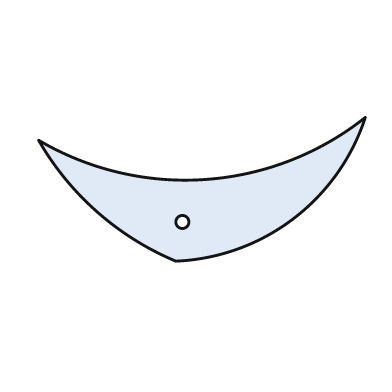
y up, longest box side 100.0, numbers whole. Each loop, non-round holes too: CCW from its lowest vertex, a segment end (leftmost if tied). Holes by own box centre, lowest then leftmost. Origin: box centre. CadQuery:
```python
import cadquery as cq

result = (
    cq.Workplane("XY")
    .moveTo(-8.0, -22.0)
    .threePointArc((28.0, -9.0), (50.0, 22.0))
    .threePointArc((1.0, 3.0), (-50.0, 15.0))
    .threePointArc((-32.0, -7.0), (-8.0, -22.0))
    .close()
    .moveTo(-6.0, -10.0)
    .circle(2.0)
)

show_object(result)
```